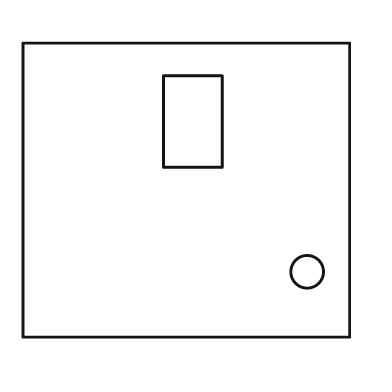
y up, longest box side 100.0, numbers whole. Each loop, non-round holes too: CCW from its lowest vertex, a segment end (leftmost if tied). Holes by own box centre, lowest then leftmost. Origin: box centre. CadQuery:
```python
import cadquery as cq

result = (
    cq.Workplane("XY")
    .moveTo(-50.0, -45.0)
    .lineTo(50.0, -45.0)
    .lineTo(50.0, 45.0)
    .lineTo(-50.0, 45.0)
    .close()
    .moveTo(37.0, -25.0)
    .circle(5.0)
    .moveTo(-7.0, 7.0)
    .lineTo(11.0, 7.0)
    .lineTo(11.0, 35.0)
    .lineTo(-7.0, 35.0)
    .close()
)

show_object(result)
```